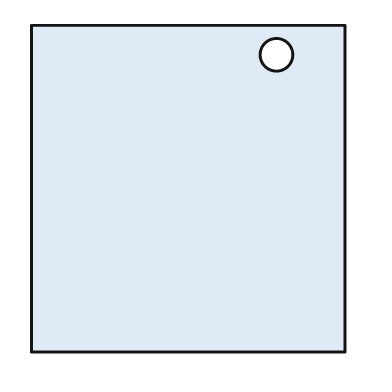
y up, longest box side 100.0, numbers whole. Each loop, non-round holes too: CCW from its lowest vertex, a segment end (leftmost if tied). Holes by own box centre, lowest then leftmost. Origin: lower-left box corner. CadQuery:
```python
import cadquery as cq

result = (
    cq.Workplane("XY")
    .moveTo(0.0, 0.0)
    .lineTo(96.0, 0.0)
    .lineTo(96.0, 100.0)
    .lineTo(0.0, 100.0)
    .close()
    .moveTo(75.0, 91.0)
    .circle(5.0)
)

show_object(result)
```